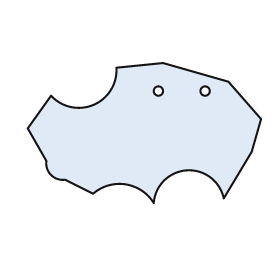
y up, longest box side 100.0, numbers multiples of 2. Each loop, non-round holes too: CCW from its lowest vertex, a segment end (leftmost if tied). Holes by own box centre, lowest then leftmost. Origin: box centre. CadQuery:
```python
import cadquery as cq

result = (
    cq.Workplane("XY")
    .moveTo(4.0, -30.0)
    .threePointArc((18.0, -16.0), (34.0, -28.0))
    .lineTo(46.0, -8.0)
    .lineTo(50.0, 6.0)
    .lineTo(36.0, 22.0)
    .lineTo(8.0, 30.0)
    .lineTo(-12.0, 28.0)
    .threePointArc((-22.0, 12.0), (-40.0, 16.0))
    .lineTo(-50.0, 2.0)
    .lineTo(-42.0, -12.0)
    .threePointArc((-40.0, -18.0), (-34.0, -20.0))
    .lineTo(-22.0, -26.0)
    .threePointArc((-8.0, -22.0), (4.0, -30.0))
    .close()
    .moveTo(6.0, 18.0)
    .circle(2.0)
    .moveTo(26.0, 18.0)
    .circle(2.0)
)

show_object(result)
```